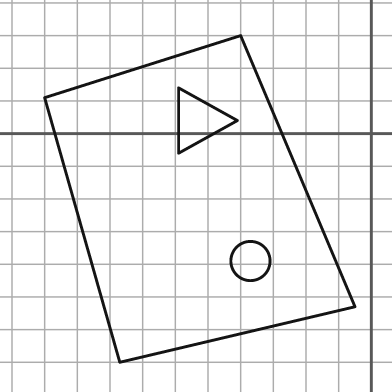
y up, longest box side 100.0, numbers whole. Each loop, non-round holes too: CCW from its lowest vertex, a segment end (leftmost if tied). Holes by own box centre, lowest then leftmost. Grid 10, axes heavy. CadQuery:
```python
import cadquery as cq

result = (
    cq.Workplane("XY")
    .moveTo(-77.0, -70.0)
    .lineTo(-5.0, -53.0)
    .lineTo(-40.0, 30.0)
    .lineTo(-100.0, 11.0)
    .close()
    .moveTo(-37.0, -39.0)
    .circle(6.0)
    .moveTo(-59.0, -6.0)
    .lineTo(-41.0, 4.0)
    .lineTo(-59.0, 14.0)
    .close()
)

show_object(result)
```